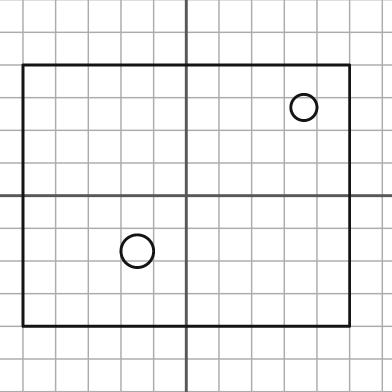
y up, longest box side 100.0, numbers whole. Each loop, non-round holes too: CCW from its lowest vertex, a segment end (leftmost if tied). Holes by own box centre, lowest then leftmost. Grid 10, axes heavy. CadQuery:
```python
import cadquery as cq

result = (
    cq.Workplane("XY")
    .moveTo(-50.0, -40.0)
    .lineTo(50.0, -40.0)
    .lineTo(50.0, 40.0)
    .lineTo(-50.0, 40.0)
    .close()
    .moveTo(-15.0, -17.0)
    .circle(5.0)
    .moveTo(36.0, 27.0)
    .circle(4.0)
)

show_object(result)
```